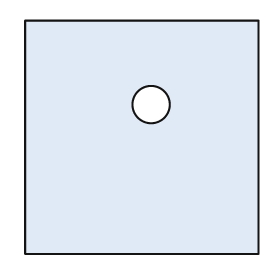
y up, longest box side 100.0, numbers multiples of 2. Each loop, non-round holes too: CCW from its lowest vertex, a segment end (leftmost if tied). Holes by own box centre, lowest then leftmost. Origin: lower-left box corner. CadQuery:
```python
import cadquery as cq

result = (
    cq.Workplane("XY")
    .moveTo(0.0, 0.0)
    .lineTo(100.0, 0.0)
    .lineTo(100.0, 100.0)
    .lineTo(0.0, 100.0)
    .close()
    .moveTo(54.0, 64.0)
    .circle(8.0)
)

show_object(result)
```